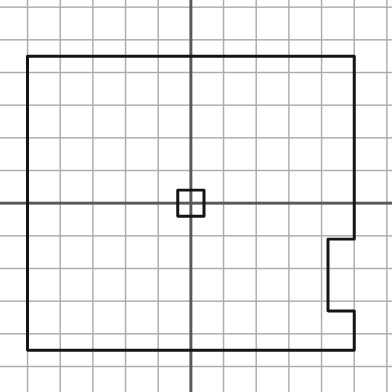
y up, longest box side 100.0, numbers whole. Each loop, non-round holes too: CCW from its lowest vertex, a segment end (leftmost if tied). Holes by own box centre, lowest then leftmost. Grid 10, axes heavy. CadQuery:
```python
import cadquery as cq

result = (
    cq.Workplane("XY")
    .moveTo(-50.0, -45.0)
    .lineTo(50.0, -45.0)
    .lineTo(50.0, -33.0)
    .lineTo(42.0, -33.0)
    .lineTo(42.0, -11.0)
    .lineTo(50.0, -11.0)
    .lineTo(50.0, 45.0)
    .lineTo(-50.0, 45.0)
    .close()
    .moveTo(-4.0, -4.0)
    .lineTo(4.0, -4.0)
    .lineTo(4.0, 4.0)
    .lineTo(-4.0, 4.0)
    .close()
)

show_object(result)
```